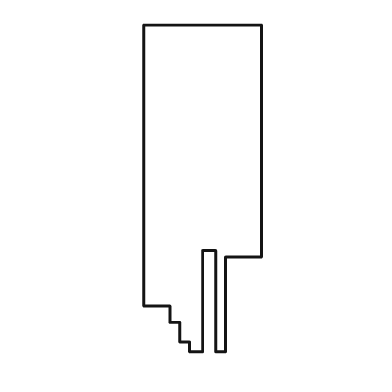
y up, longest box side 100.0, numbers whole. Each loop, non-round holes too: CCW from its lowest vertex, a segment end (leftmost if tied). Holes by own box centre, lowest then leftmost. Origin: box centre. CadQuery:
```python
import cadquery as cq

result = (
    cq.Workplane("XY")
    .moveTo(-4.0, -50.0)
    .lineTo(0.0, -50.0)
    .lineTo(0.0, -19.0)
    .lineTo(4.0, -19.0)
    .lineTo(4.0, -50.0)
    .lineTo(7.0, -50.0)
    .lineTo(7.0, -21.0)
    .lineTo(18.0, -21.0)
    .lineTo(18.0, 50.0)
    .lineTo(-18.0, 50.0)
    .lineTo(-18.0, -36.0)
    .lineTo(-10.0, -36.0)
    .lineTo(-10.0, -41.0)
    .lineTo(-7.0, -41.0)
    .lineTo(-7.0, -47.0)
    .lineTo(-4.0, -47.0)
    .close()
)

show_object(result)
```